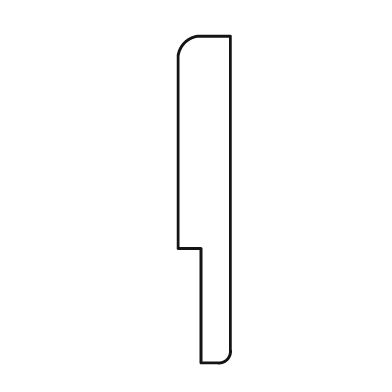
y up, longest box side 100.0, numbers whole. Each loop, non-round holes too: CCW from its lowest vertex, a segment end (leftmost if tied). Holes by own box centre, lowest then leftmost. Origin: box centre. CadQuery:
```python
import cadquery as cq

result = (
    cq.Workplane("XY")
    .moveTo(-1.0, -50.0)
    .lineTo(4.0, -50.0)
    .threePointArc((7.0, -49.0), (8.0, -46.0))
    .lineTo(8.0, 50.0)
    .lineTo(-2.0, 50.0)
    .threePointArc((-6.0, 48.0), (-8.0, 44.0))
    .lineTo(-8.0, -15.0)
    .lineTo(-1.0, -15.0)
    .close()
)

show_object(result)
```